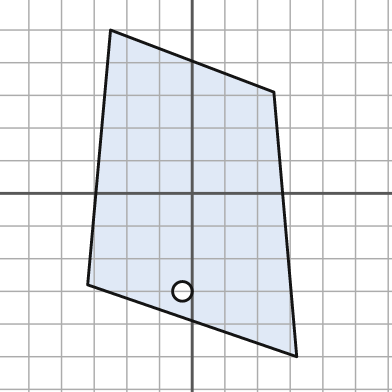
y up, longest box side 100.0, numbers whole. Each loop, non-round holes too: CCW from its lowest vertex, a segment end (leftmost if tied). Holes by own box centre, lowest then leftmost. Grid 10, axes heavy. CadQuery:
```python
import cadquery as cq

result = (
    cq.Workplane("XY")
    .moveTo(32.0, -50.0)
    .lineTo(25.0, 31.0)
    .lineTo(-25.0, 50.0)
    .lineTo(-32.0, -28.0)
    .close()
    .moveTo(-3.0, -30.0)
    .circle(3.0)
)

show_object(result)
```